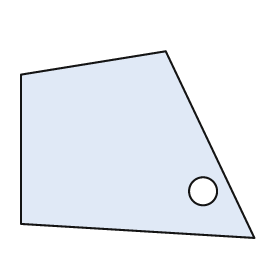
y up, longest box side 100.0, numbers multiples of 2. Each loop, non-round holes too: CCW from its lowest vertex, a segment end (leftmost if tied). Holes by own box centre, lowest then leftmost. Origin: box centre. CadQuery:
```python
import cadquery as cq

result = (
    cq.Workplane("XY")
    .moveTo(50.0, -40.0)
    .lineTo(12.0, 40.0)
    .lineTo(-50.0, 30.0)
    .lineTo(-50.0, -34.0)
    .close()
    .moveTo(28.0, -20.0)
    .circle(6.0)
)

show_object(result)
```